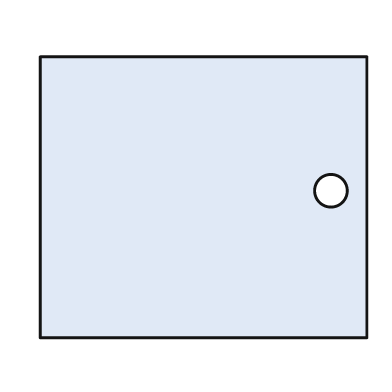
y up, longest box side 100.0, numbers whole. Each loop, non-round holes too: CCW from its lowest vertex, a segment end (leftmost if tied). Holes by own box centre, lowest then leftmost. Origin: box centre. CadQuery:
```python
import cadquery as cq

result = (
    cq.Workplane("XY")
    .moveTo(-50.0, -43.0)
    .lineTo(50.0, -43.0)
    .lineTo(50.0, 43.0)
    .lineTo(-50.0, 43.0)
    .close()
    .moveTo(39.0, 2.0)
    .circle(5.0)
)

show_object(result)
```